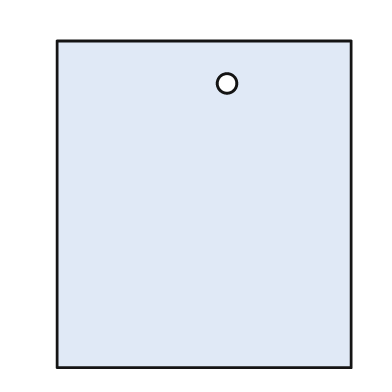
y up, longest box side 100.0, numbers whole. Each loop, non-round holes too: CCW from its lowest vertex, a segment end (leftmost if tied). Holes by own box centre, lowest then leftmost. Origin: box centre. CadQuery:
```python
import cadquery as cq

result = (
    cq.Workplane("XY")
    .moveTo(-45.0, -50.0)
    .lineTo(45.0, -50.0)
    .lineTo(45.0, 50.0)
    .lineTo(-45.0, 50.0)
    .close()
    .moveTo(7.0, 37.0)
    .circle(3.0)
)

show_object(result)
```